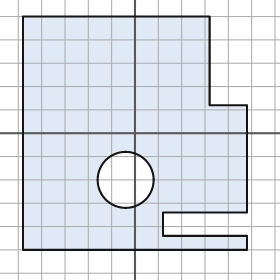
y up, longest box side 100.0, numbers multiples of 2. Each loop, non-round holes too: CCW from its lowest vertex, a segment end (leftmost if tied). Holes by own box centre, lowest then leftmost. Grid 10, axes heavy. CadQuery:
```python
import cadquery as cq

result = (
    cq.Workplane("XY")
    .moveTo(-48.0, -50.0)
    .lineTo(48.0, -50.0)
    .lineTo(48.0, -44.0)
    .lineTo(12.0, -44.0)
    .lineTo(12.0, -34.0)
    .lineTo(48.0, -34.0)
    .lineTo(48.0, 12.0)
    .lineTo(32.0, 12.0)
    .lineTo(32.0, 50.0)
    .lineTo(-48.0, 50.0)
    .close()
    .moveTo(-4.0, -20.0)
    .circle(12.0)
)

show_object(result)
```